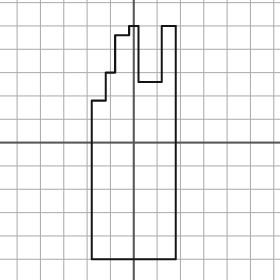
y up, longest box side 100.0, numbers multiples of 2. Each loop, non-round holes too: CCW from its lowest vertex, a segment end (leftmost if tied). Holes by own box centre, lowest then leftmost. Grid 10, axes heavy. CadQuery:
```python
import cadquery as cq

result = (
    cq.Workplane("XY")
    .moveTo(-18.0, -50.0)
    .lineTo(18.0, -50.0)
    .lineTo(18.0, 50.0)
    .lineTo(12.0, 50.0)
    .lineTo(12.0, 26.0)
    .lineTo(2.0, 26.0)
    .lineTo(2.0, 50.0)
    .lineTo(-2.0, 50.0)
    .lineTo(-2.0, 46.0)
    .lineTo(-8.0, 46.0)
    .lineTo(-8.0, 30.0)
    .lineTo(-12.0, 30.0)
    .lineTo(-12.0, 18.0)
    .lineTo(-18.0, 18.0)
    .close()
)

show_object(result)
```